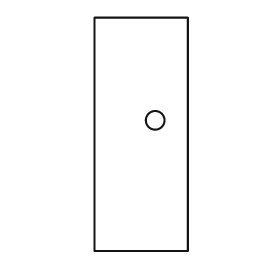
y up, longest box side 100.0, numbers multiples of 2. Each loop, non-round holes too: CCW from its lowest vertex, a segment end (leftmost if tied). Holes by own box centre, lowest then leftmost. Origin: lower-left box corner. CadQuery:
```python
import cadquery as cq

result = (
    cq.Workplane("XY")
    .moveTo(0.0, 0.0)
    .lineTo(40.0, 0.0)
    .lineTo(40.0, 100.0)
    .lineTo(0.0, 100.0)
    .close()
    .moveTo(26.0, 56.0)
    .circle(4.0)
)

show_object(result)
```